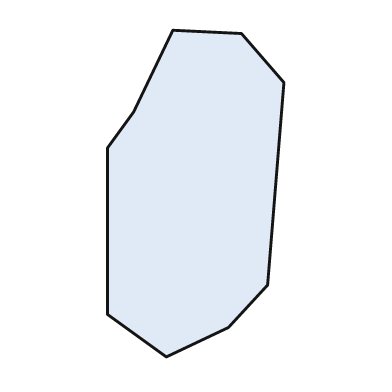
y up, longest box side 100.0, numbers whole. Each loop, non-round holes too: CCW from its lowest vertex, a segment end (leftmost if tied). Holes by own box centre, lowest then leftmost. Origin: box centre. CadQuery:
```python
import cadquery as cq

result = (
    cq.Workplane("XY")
    .moveTo(-9.0, -50.0)
    .lineTo(10.0, -41.0)
    .lineTo(22.0, -28.0)
    .lineTo(27.0, 34.0)
    .lineTo(14.0, 49.0)
    .lineTo(-7.0, 50.0)
    .lineTo(-19.0, 25.0)
    .lineTo(-27.0, 14.0)
    .lineTo(-27.0, -37.0)
    .close()
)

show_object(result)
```